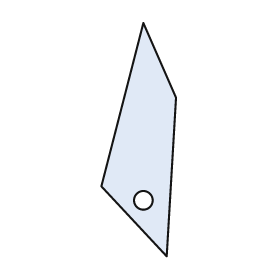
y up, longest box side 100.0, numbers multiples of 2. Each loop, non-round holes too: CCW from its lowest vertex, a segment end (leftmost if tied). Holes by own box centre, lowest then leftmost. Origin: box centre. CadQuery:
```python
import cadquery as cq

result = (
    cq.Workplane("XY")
    .moveTo(12.0, -50.0)
    .lineTo(16.0, 18.0)
    .lineTo(2.0, 50.0)
    .lineTo(-16.0, -20.0)
    .close()
    .moveTo(2.0, -26.0)
    .circle(4.0)
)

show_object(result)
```